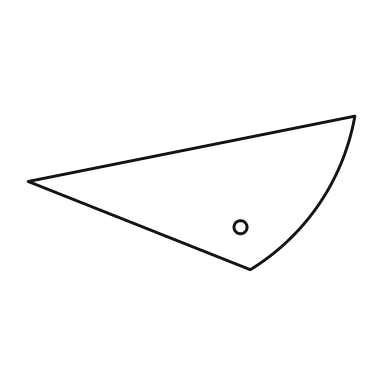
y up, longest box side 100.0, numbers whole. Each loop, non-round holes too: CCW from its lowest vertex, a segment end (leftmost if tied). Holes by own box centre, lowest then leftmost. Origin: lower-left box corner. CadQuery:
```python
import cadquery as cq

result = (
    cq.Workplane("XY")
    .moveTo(68.0, 0.0)
    .threePointArc((89.0, 20.0), (100.0, 47.0))
    .lineTo(0.0, 27.0)
    .close()
    .moveTo(65.0, 13.0)
    .circle(2.0)
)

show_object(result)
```